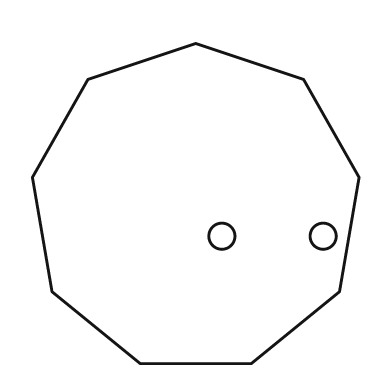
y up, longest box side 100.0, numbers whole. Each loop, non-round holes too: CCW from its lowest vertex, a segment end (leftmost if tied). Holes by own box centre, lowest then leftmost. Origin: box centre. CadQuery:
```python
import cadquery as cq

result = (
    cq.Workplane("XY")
    .moveTo(-17.0, -49.0)
    .lineTo(17.0, -49.0)
    .lineTo(44.0, -27.0)
    .lineTo(50.0, 8.0)
    .lineTo(33.0, 38.0)
    .lineTo(0.0, 49.0)
    .lineTo(-33.0, 38.0)
    .lineTo(-50.0, 8.0)
    .lineTo(-44.0, -27.0)
    .close()
    .moveTo(8.0, -10.0)
    .circle(4.0)
    .moveTo(39.0, -10.0)
    .circle(4.0)
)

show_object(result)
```